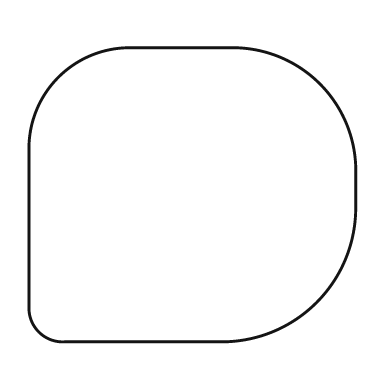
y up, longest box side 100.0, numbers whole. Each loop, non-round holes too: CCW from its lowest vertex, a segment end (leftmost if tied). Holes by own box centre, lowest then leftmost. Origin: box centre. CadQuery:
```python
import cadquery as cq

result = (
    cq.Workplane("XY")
    .moveTo(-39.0, -45.0)
    .lineTo(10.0, -45.0)
    .threePointArc((38.0, -33.0), (50.0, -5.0))
    .lineTo(50.0, 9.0)
    .threePointArc((39.0, 34.0), (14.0, 45.0))
    .lineTo(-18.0, 45.0)
    .threePointArc((-41.0, 36.0), (-50.0, 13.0))
    .lineTo(-50.0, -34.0)
    .threePointArc((-47.0, -42.0), (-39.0, -45.0))
    .close()
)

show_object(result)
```